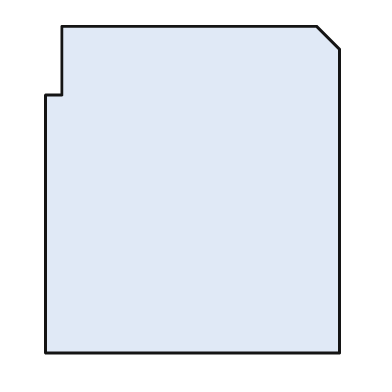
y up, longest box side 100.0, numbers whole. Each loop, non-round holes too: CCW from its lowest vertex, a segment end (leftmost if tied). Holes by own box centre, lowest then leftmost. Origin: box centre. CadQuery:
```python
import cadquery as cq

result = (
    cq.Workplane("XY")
    .moveTo(-45.0, -50.0)
    .lineTo(45.0, -50.0)
    .lineTo(45.0, 43.0)
    .lineTo(38.0, 50.0)
    .lineTo(-40.0, 50.0)
    .lineTo(-40.0, 29.0)
    .lineTo(-45.0, 29.0)
    .close()
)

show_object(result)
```